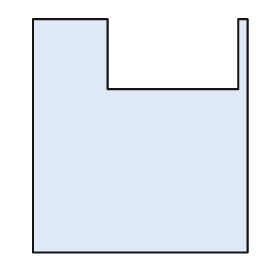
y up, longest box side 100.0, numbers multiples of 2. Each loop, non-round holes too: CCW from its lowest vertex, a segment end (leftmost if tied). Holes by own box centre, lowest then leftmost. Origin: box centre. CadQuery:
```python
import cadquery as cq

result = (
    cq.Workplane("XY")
    .moveTo(-46.0, -50.0)
    .lineTo(46.0, -50.0)
    .lineTo(46.0, 50.0)
    .lineTo(42.0, 50.0)
    .lineTo(42.0, 20.0)
    .lineTo(-14.0, 20.0)
    .lineTo(-14.0, 50.0)
    .lineTo(-46.0, 50.0)
    .close()
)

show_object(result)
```